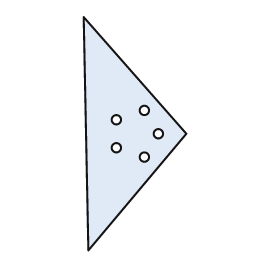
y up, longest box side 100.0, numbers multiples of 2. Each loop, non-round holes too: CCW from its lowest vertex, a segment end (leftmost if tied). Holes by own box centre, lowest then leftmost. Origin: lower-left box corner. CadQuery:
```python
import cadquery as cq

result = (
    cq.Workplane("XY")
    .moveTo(2.0, 0.0)
    .lineTo(44.0, 50.0)
    .lineTo(0.0, 100.0)
    .close()
    .moveTo(26.0, 40.0)
    .circle(2.0)
    .moveTo(14.0, 44.0)
    .circle(2.0)
    .moveTo(32.0, 50.0)
    .circle(2.0)
    .moveTo(14.0, 56.0)
    .circle(2.0)
    .moveTo(26.0, 60.0)
    .circle(2.0)
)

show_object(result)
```